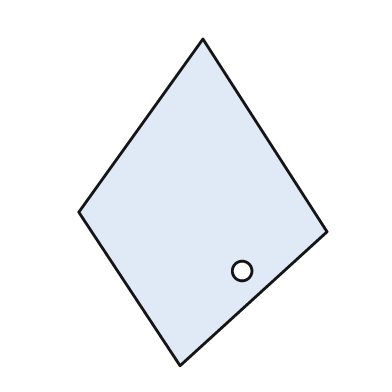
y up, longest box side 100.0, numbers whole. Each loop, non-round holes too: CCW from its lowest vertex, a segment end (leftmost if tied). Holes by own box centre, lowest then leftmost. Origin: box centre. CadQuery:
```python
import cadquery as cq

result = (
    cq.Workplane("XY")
    .moveTo(-7.0, -50.0)
    .lineTo(38.0, -9.0)
    .lineTo(0.0, 50.0)
    .lineTo(-38.0, -3.0)
    .close()
    .moveTo(12.0, -21.0)
    .circle(3.0)
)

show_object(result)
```